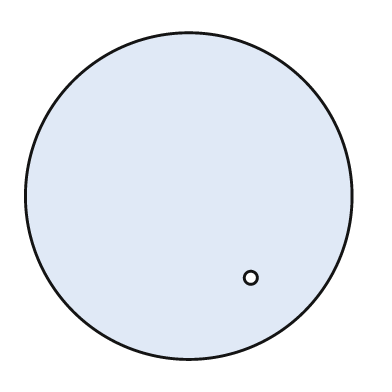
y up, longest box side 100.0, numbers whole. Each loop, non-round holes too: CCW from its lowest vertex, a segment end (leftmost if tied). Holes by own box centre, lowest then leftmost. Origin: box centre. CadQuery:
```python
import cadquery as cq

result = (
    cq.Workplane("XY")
    .moveTo(0.0, 0.0)
    .circle(50.0)
    .moveTo(19.0, -25.0)
    .circle(2.0)
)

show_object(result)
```